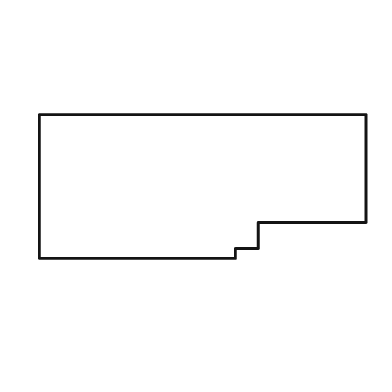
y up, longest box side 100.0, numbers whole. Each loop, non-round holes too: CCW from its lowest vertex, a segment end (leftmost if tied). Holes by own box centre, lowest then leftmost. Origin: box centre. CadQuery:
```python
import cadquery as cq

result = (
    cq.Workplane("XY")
    .moveTo(-50.0, -22.0)
    .lineTo(10.0, -22.0)
    .lineTo(10.0, -19.0)
    .lineTo(17.0, -19.0)
    .lineTo(17.0, -11.0)
    .lineTo(50.0, -11.0)
    .lineTo(50.0, 22.0)
    .lineTo(-50.0, 22.0)
    .close()
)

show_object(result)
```